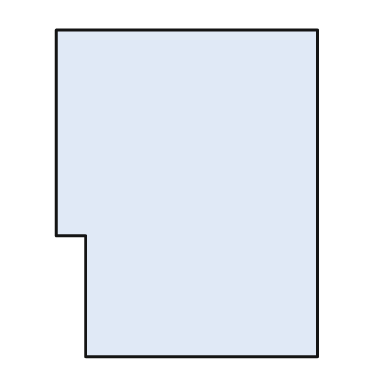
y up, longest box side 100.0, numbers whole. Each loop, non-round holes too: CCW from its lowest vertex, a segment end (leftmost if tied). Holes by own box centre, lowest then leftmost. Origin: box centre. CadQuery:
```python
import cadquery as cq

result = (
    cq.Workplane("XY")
    .moveTo(-31.0, -50.0)
    .lineTo(40.0, -50.0)
    .lineTo(40.0, 50.0)
    .lineTo(-40.0, 50.0)
    .lineTo(-40.0, -13.0)
    .lineTo(-31.0, -13.0)
    .close()
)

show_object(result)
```